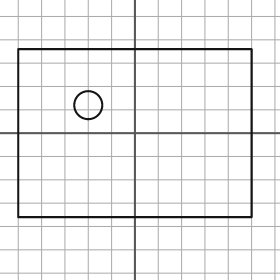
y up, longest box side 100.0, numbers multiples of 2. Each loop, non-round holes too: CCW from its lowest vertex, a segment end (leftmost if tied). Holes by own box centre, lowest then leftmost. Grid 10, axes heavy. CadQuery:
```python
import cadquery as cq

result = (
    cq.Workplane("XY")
    .moveTo(-50.0, -36.0)
    .lineTo(50.0, -36.0)
    .lineTo(50.0, 36.0)
    .lineTo(-50.0, 36.0)
    .close()
    .moveTo(-20.0, 12.0)
    .circle(6.0)
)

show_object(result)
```